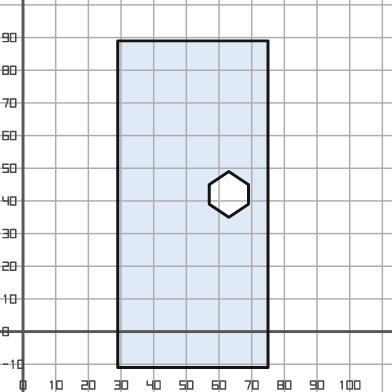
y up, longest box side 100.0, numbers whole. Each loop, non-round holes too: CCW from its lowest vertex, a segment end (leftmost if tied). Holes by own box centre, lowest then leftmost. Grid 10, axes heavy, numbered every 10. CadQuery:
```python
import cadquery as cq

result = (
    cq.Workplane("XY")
    .moveTo(29.0, -11.0)
    .lineTo(75.0, -11.0)
    .lineTo(75.0, 89.0)
    .lineTo(29.0, 89.0)
    .close()
    .moveTo(63.0, 35.0)
    .lineTo(69.0, 39.0)
    .lineTo(69.0, 45.0)
    .lineTo(63.0, 49.0)
    .lineTo(57.0, 45.0)
    .lineTo(57.0, 39.0)
    .close()
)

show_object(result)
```